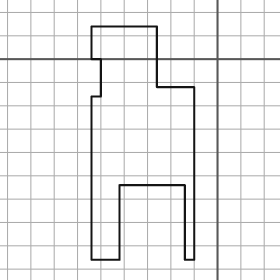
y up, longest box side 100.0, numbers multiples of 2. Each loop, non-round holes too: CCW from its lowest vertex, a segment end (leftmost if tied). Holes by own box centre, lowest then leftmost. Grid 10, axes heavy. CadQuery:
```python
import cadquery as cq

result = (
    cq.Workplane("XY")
    .moveTo(-54.0, -86.0)
    .lineTo(-42.0, -86.0)
    .lineTo(-42.0, -54.0)
    .lineTo(-14.0, -54.0)
    .lineTo(-14.0, -86.0)
    .lineTo(-10.0, -86.0)
    .lineTo(-10.0, -12.0)
    .lineTo(-26.0, -12.0)
    .lineTo(-26.0, 14.0)
    .lineTo(-54.0, 14.0)
    .lineTo(-54.0, 0.0)
    .lineTo(-50.0, 0.0)
    .lineTo(-50.0, -16.0)
    .lineTo(-54.0, -16.0)
    .close()
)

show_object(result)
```